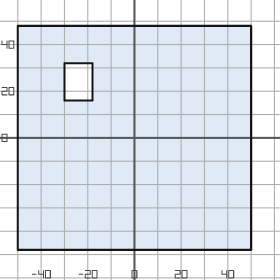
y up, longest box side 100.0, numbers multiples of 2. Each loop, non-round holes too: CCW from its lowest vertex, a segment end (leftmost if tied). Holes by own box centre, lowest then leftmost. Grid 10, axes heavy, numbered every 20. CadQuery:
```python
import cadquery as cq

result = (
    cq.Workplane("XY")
    .moveTo(-50.0, -48.0)
    .lineTo(50.0, -48.0)
    .lineTo(50.0, 48.0)
    .lineTo(-50.0, 48.0)
    .close()
    .moveTo(-30.0, 16.0)
    .lineTo(-18.0, 16.0)
    .lineTo(-18.0, 32.0)
    .lineTo(-30.0, 32.0)
    .close()
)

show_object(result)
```